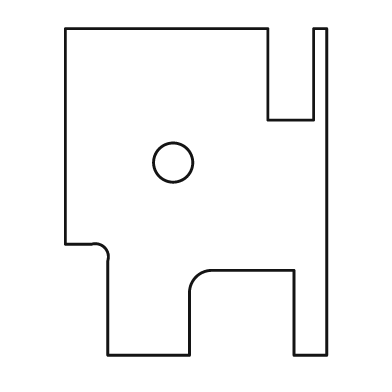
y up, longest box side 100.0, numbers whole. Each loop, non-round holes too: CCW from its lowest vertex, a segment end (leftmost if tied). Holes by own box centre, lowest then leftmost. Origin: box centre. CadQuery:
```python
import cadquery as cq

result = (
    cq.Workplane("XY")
    .moveTo(-27.0, -50.0)
    .lineTo(-2.0, -50.0)
    .lineTo(-2.0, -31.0)
    .threePointArc((0.0, -26.0), (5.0, -24.0))
    .lineTo(30.0, -24.0)
    .lineTo(30.0, -50.0)
    .lineTo(40.0, -50.0)
    .lineTo(40.0, 50.0)
    .lineTo(36.0, 50.0)
    .lineTo(36.0, 22.0)
    .lineTo(22.0, 22.0)
    .lineTo(22.0, 50.0)
    .lineTo(-40.0, 50.0)
    .lineTo(-40.0, -16.0)
    .lineTo(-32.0, -16.0)
    .threePointArc((-28.0, -17.0), (-27.0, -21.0))
    .close()
    .moveTo(-7.0, 9.0)
    .circle(6.0)
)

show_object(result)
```